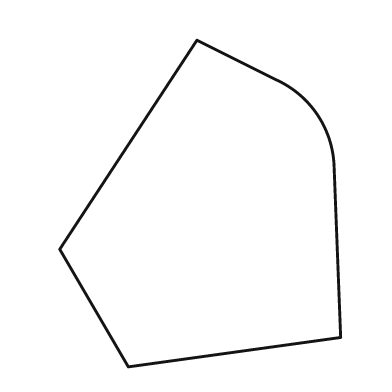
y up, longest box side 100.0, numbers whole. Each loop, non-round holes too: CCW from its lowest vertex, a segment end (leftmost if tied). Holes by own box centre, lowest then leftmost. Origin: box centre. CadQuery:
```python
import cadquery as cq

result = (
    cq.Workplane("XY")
    .moveTo(-22.0, -50.0)
    .lineTo(43.0, -41.0)
    .lineTo(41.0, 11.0)
    .threePointArc((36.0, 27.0), (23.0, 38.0))
    .lineTo(-1.0, 50.0)
    .lineTo(-43.0, -14.0)
    .close()
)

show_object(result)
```